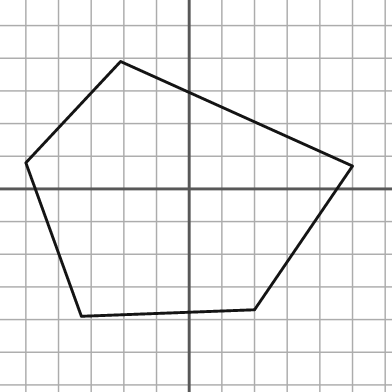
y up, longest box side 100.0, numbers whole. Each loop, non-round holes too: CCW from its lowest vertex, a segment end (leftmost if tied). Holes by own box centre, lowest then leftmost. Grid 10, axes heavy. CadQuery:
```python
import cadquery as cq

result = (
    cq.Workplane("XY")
    .moveTo(-33.0, -39.0)
    .lineTo(20.0, -37.0)
    .lineTo(50.0, 7.0)
    .lineTo(-21.0, 39.0)
    .lineTo(-50.0, 8.0)
    .close()
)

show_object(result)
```